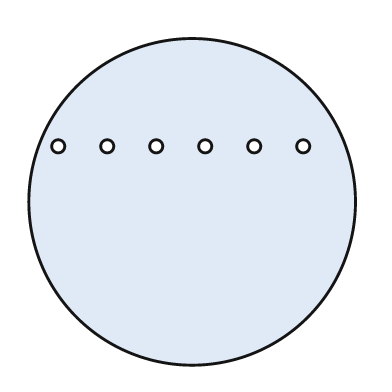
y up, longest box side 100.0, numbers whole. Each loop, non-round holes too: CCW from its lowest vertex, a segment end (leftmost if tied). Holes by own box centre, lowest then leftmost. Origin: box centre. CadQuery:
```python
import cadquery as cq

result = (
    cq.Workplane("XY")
    .moveTo(0.0, 0.0)
    .circle(50.0)
    .moveTo(-41.0, 17.0)
    .circle(2.0)
    .moveTo(-26.0, 17.0)
    .circle(2.0)
    .moveTo(-11.0, 17.0)
    .circle(2.0)
    .moveTo(4.0, 17.0)
    .circle(2.0)
    .moveTo(19.0, 17.0)
    .circle(2.0)
    .moveTo(34.0, 17.0)
    .circle(2.0)
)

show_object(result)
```